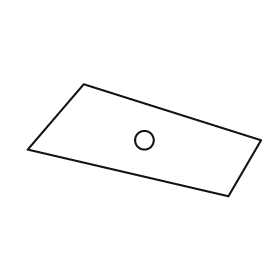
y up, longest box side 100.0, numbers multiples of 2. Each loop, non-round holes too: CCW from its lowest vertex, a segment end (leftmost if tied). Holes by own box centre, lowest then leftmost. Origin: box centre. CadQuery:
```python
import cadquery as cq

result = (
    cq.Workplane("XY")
    .moveTo(36.0, -24.0)
    .lineTo(50.0, 0.0)
    .lineTo(-26.0, 24.0)
    .lineTo(-50.0, -4.0)
    .close()
    .moveTo(0.0, 0.0)
    .circle(4.0)
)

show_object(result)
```